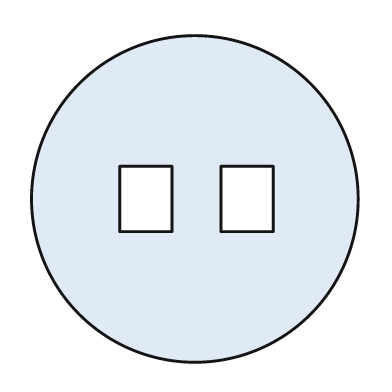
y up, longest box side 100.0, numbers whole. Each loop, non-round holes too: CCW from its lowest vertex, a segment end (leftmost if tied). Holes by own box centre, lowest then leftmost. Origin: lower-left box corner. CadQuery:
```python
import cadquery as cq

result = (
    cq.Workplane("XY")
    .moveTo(50.0, 50.0)
    .circle(50.0)
    .moveTo(27.0, 40.0)
    .lineTo(43.0, 40.0)
    .lineTo(43.0, 60.0)
    .lineTo(27.0, 60.0)
    .close()
    .moveTo(58.0, 40.0)
    .lineTo(74.0, 40.0)
    .lineTo(74.0, 60.0)
    .lineTo(58.0, 60.0)
    .close()
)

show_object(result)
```